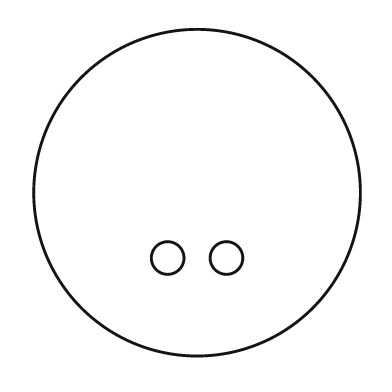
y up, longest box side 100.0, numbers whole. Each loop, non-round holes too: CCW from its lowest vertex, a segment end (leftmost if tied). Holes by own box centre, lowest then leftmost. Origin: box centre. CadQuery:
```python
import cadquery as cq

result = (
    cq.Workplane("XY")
    .moveTo(0.0, 0.0)
    .circle(50.0)
    .moveTo(-9.0, -20.0)
    .circle(5.0)
    .moveTo(9.0, -20.0)
    .circle(5.0)
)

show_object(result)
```